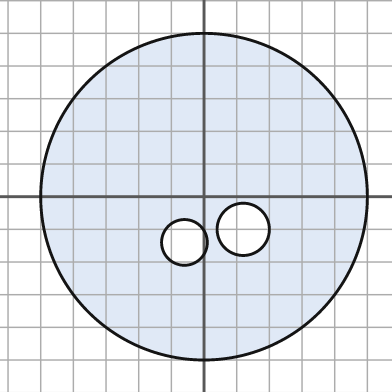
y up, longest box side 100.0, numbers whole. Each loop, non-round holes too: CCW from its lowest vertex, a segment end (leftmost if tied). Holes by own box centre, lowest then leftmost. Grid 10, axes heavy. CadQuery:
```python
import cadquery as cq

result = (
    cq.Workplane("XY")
    .moveTo(0.0, 0.0)
    .circle(50.0)
    .moveTo(-6.0, -14.0)
    .circle(7.0)
    .moveTo(12.0, -10.0)
    .circle(8.0)
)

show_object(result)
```